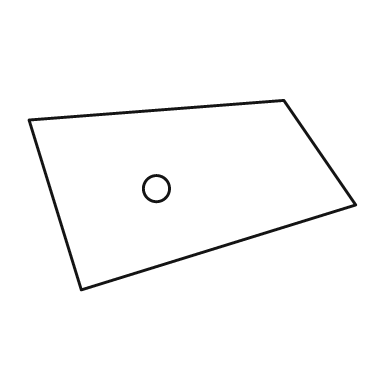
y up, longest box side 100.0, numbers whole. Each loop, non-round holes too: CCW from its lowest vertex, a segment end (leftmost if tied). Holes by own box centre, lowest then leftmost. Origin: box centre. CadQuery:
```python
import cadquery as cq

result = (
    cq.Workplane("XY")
    .moveTo(-34.0, -29.0)
    .lineTo(50.0, -3.0)
    .lineTo(28.0, 29.0)
    .lineTo(-50.0, 23.0)
    .close()
    .moveTo(-11.0, 2.0)
    .circle(4.0)
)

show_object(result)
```